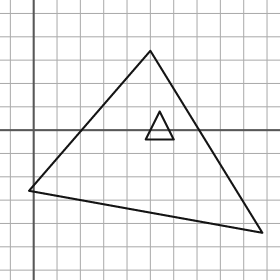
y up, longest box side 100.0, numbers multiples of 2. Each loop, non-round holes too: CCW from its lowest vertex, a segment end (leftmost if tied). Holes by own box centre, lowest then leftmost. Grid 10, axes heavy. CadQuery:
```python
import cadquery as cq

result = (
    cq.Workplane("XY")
    .moveTo(98.0, -44.0)
    .lineTo(50.0, 34.0)
    .lineTo(-2.0, -26.0)
    .close()
    .moveTo(48.0, -4.0)
    .lineTo(60.0, -4.0)
    .lineTo(54.0, 8.0)
    .close()
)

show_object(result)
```